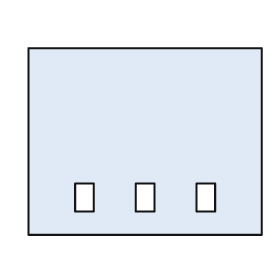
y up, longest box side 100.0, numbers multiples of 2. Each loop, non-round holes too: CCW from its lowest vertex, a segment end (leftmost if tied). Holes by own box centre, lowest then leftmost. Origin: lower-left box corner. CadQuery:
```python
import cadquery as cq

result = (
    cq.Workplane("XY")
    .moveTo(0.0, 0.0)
    .lineTo(100.0, 0.0)
    .lineTo(100.0, 80.0)
    .lineTo(0.0, 80.0)
    .close()
    .moveTo(20.0, 10.0)
    .lineTo(28.0, 10.0)
    .lineTo(28.0, 22.0)
    .lineTo(20.0, 22.0)
    .close()
    .moveTo(46.0, 10.0)
    .lineTo(54.0, 10.0)
    .lineTo(54.0, 22.0)
    .lineTo(46.0, 22.0)
    .close()
    .moveTo(72.0, 10.0)
    .lineTo(80.0, 10.0)
    .lineTo(80.0, 22.0)
    .lineTo(72.0, 22.0)
    .close()
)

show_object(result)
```